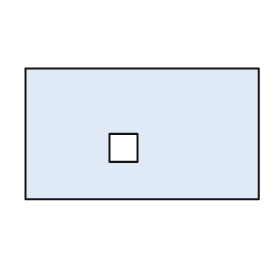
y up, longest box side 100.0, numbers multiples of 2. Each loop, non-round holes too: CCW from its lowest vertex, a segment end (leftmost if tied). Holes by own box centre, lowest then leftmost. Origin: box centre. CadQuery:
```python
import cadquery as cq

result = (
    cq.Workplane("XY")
    .moveTo(-50.0, -28.0)
    .lineTo(50.0, -28.0)
    .lineTo(50.0, 28.0)
    .lineTo(-50.0, 28.0)
    .close()
    .moveTo(-14.0, -12.0)
    .lineTo(-2.0, -12.0)
    .lineTo(-2.0, 0.0)
    .lineTo(-14.0, 0.0)
    .close()
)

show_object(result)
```